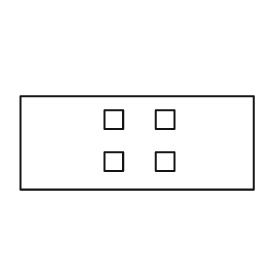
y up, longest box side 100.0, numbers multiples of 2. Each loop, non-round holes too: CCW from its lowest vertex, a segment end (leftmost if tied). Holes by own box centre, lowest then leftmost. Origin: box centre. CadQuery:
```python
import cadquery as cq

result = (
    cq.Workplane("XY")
    .moveTo(-50.0, -20.0)
    .lineTo(50.0, -20.0)
    .lineTo(50.0, 20.0)
    .lineTo(-50.0, 20.0)
    .close()
    .moveTo(-14.0, -12.0)
    .lineTo(-6.0, -12.0)
    .lineTo(-6.0, -4.0)
    .lineTo(-14.0, -4.0)
    .close()
    .moveTo(8.0, -12.0)
    .lineTo(16.0, -12.0)
    .lineTo(16.0, -4.0)
    .lineTo(8.0, -4.0)
    .close()
    .moveTo(-14.0, 6.0)
    .lineTo(-6.0, 6.0)
    .lineTo(-6.0, 14.0)
    .lineTo(-14.0, 14.0)
    .close()
    .moveTo(8.0, 6.0)
    .lineTo(16.0, 6.0)
    .lineTo(16.0, 14.0)
    .lineTo(8.0, 14.0)
    .close()
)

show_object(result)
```